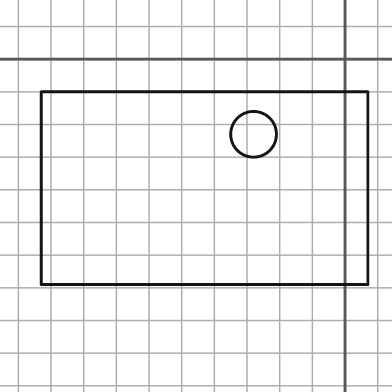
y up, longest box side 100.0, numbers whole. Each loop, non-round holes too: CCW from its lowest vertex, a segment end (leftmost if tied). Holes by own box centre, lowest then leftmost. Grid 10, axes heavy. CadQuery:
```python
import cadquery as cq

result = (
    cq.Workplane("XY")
    .moveTo(-93.0, -69.0)
    .lineTo(7.0, -69.0)
    .lineTo(7.0, -10.0)
    .lineTo(-93.0, -10.0)
    .close()
    .moveTo(-28.0, -23.0)
    .circle(7.0)
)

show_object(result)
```